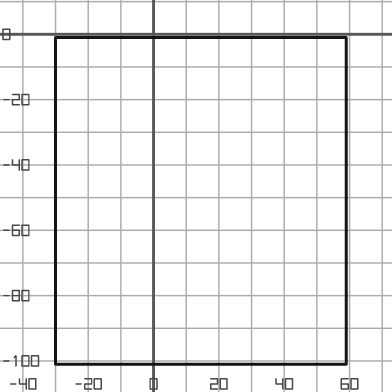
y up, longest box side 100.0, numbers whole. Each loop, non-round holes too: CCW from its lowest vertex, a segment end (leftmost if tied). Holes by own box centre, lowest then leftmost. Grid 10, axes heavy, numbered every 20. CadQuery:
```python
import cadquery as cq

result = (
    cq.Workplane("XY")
    .moveTo(-30.0, -101.0)
    .lineTo(59.0, -101.0)
    .lineTo(59.0, -1.0)
    .lineTo(-30.0, -1.0)
    .close()
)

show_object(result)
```